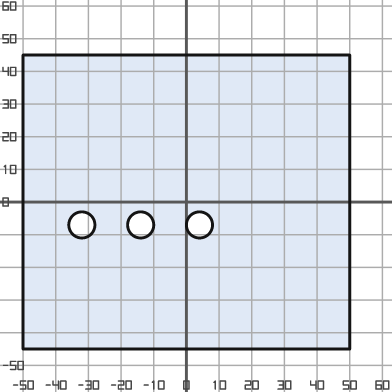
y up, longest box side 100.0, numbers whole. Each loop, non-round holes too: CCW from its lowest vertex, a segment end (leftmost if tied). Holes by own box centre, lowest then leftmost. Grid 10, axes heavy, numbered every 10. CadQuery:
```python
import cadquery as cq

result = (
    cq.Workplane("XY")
    .moveTo(-50.0, -45.0)
    .lineTo(50.0, -45.0)
    .lineTo(50.0, 45.0)
    .lineTo(-50.0, 45.0)
    .close()
    .moveTo(-32.0, -7.0)
    .circle(4.0)
    .moveTo(-14.0, -7.0)
    .circle(4.0)
    .moveTo(4.0, -7.0)
    .circle(4.0)
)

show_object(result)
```